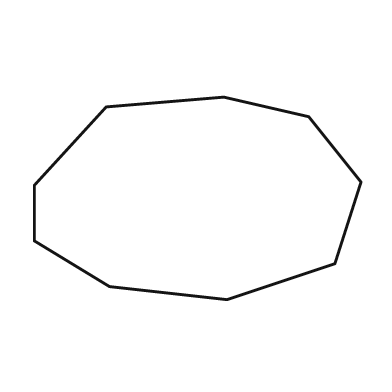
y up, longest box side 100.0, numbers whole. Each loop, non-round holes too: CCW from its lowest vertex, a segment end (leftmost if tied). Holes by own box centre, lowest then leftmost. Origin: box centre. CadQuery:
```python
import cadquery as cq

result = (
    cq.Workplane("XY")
    .moveTo(9.0, -31.0)
    .lineTo(42.0, -20.0)
    .lineTo(50.0, 5.0)
    .lineTo(34.0, 25.0)
    .lineTo(8.0, 31.0)
    .lineTo(-28.0, 28.0)
    .lineTo(-50.0, 4.0)
    .lineTo(-50.0, -13.0)
    .lineTo(-27.0, -27.0)
    .close()
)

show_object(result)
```